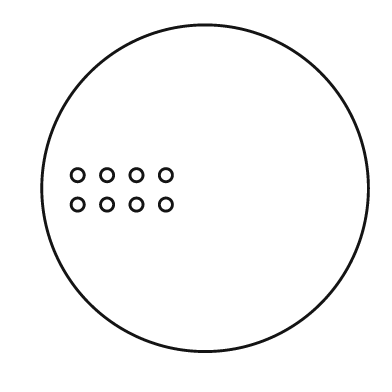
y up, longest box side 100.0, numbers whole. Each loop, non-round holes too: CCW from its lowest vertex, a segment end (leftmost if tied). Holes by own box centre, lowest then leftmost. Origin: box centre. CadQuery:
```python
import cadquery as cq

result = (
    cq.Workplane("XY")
    .moveTo(0.0, 0.0)
    .circle(50.0)
    .moveTo(-39.0, -5.0)
    .circle(2.0)
    .moveTo(-30.0, -5.0)
    .circle(2.0)
    .moveTo(-21.0, -5.0)
    .circle(2.0)
    .moveTo(-12.0, -5.0)
    .circle(2.0)
    .moveTo(-39.0, 4.0)
    .circle(2.0)
    .moveTo(-30.0, 4.0)
    .circle(2.0)
    .moveTo(-21.0, 4.0)
    .circle(2.0)
    .moveTo(-12.0, 4.0)
    .circle(2.0)
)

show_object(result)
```